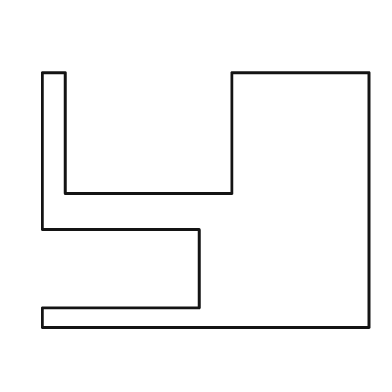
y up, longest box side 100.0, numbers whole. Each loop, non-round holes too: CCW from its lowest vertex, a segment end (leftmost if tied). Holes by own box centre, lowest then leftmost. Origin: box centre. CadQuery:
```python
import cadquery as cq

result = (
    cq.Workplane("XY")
    .moveTo(-50.0, -39.0)
    .lineTo(50.0, -39.0)
    .lineTo(50.0, 39.0)
    .lineTo(8.0, 39.0)
    .lineTo(8.0, 2.0)
    .lineTo(-43.0, 2.0)
    .lineTo(-43.0, 39.0)
    .lineTo(-50.0, 39.0)
    .lineTo(-50.0, -9.0)
    .lineTo(-2.0, -9.0)
    .lineTo(-2.0, -33.0)
    .lineTo(-50.0, -33.0)
    .close()
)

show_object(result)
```